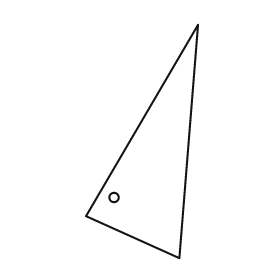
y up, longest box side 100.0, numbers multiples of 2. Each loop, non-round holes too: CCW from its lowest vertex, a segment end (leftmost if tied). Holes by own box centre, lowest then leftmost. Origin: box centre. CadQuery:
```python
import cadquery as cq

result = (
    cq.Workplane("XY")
    .moveTo(16.0, -50.0)
    .lineTo(24.0, 50.0)
    .lineTo(-24.0, -32.0)
    .close()
    .moveTo(-12.0, -24.0)
    .circle(2.0)
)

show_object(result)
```